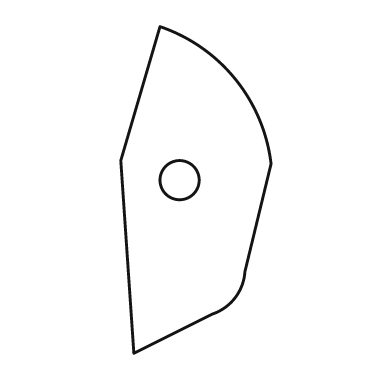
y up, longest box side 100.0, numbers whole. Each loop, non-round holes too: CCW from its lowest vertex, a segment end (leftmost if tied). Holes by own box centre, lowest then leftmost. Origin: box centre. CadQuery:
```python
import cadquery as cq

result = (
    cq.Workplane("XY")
    .moveTo(-19.0, -50.0)
    .lineTo(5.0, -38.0)
    .threePointArc((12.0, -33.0), (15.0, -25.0))
    .lineTo(23.0, 8.0)
    .threePointArc((12.0, 34.0), (-11.0, 50.0))
    .lineTo(-23.0, 9.0)
    .close()
    .moveTo(-5.0, 3.0)
    .circle(6.0)
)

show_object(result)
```